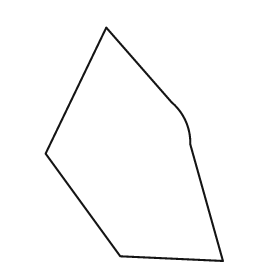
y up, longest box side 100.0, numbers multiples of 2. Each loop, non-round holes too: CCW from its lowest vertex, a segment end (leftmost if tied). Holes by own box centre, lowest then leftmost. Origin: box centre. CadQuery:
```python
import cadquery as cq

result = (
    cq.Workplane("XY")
    .moveTo(38.0, -50.0)
    .lineTo(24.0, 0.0)
    .threePointArc((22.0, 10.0), (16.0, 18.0))
    .lineTo(-12.0, 50.0)
    .lineTo(-38.0, -4.0)
    .lineTo(-6.0, -48.0)
    .close()
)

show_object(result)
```